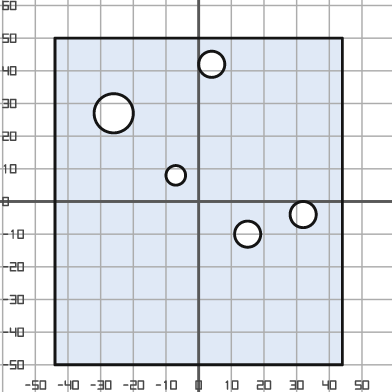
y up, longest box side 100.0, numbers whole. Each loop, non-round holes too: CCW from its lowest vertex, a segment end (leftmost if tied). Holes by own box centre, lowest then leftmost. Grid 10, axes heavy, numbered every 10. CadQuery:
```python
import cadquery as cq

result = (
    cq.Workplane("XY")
    .moveTo(-44.0, -50.0)
    .lineTo(44.0, -50.0)
    .lineTo(44.0, 50.0)
    .lineTo(-44.0, 50.0)
    .close()
    .moveTo(15.0, -10.0)
    .circle(4.0)
    .moveTo(32.0, -4.0)
    .circle(4.0)
    .moveTo(-7.0, 8.0)
    .circle(3.0)
    .moveTo(-26.0, 27.0)
    .circle(6.0)
    .moveTo(4.0, 42.0)
    .circle(4.0)
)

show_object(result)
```